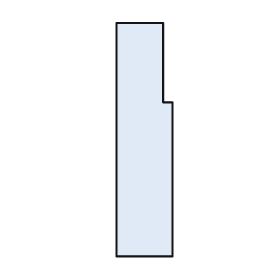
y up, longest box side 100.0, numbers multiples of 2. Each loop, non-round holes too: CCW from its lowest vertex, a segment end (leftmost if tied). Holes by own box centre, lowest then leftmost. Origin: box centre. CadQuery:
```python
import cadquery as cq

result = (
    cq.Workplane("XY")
    .moveTo(-12.0, -50.0)
    .lineTo(12.0, -50.0)
    .lineTo(12.0, 16.0)
    .lineTo(8.0, 16.0)
    .lineTo(8.0, 50.0)
    .lineTo(-12.0, 50.0)
    .close()
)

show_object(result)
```